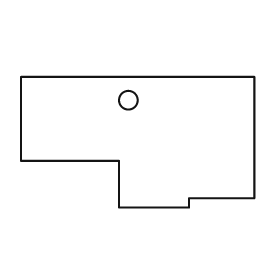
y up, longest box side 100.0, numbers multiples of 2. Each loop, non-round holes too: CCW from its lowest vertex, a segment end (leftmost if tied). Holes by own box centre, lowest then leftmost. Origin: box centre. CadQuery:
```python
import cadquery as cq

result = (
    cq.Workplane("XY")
    .moveTo(-8.0, -28.0)
    .lineTo(22.0, -28.0)
    .lineTo(22.0, -24.0)
    .lineTo(50.0, -24.0)
    .lineTo(50.0, 28.0)
    .lineTo(-50.0, 28.0)
    .lineTo(-50.0, -8.0)
    .lineTo(-8.0, -8.0)
    .close()
    .moveTo(-4.0, 18.0)
    .circle(4.0)
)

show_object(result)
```